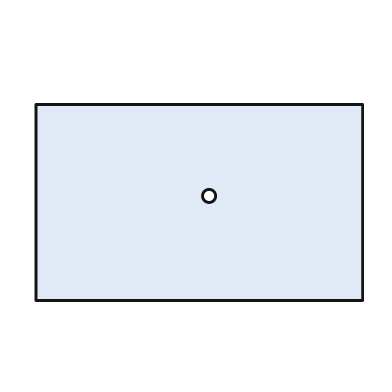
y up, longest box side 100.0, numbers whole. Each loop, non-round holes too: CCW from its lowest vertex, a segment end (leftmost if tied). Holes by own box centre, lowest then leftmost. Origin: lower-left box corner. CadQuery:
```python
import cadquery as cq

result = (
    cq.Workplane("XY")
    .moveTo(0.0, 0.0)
    .lineTo(100.0, 0.0)
    .lineTo(100.0, 60.0)
    .lineTo(0.0, 60.0)
    .close()
    .moveTo(53.0, 32.0)
    .circle(2.0)
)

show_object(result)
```